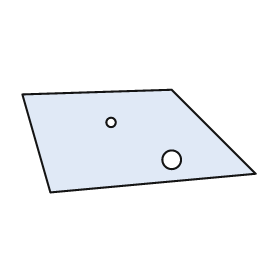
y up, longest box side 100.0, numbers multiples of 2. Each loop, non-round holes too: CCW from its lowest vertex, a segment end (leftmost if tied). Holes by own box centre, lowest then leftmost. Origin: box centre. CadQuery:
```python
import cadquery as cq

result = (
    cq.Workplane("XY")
    .moveTo(-38.0, -22.0)
    .lineTo(50.0, -14.0)
    .lineTo(14.0, 22.0)
    .lineTo(-50.0, 20.0)
    .close()
    .moveTo(14.0, -8.0)
    .circle(4.0)
    .moveTo(-12.0, 8.0)
    .circle(2.0)
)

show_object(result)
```